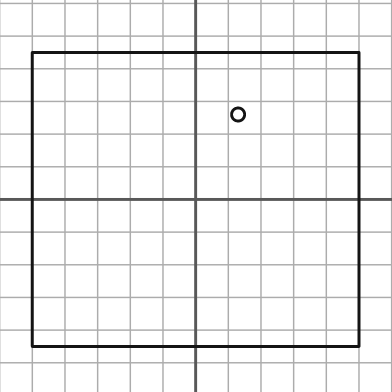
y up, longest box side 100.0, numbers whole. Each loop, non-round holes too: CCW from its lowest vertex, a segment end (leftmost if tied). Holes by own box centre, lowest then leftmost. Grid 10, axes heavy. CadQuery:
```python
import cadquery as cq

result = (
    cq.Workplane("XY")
    .moveTo(-50.0, -45.0)
    .lineTo(50.0, -45.0)
    .lineTo(50.0, 45.0)
    .lineTo(-50.0, 45.0)
    .close()
    .moveTo(13.0, 26.0)
    .circle(2.0)
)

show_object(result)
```